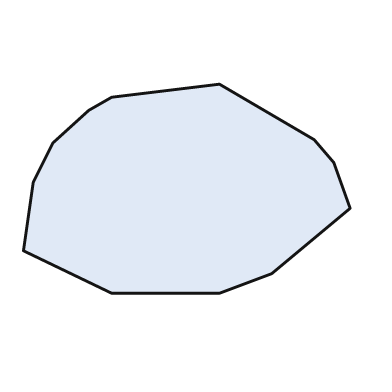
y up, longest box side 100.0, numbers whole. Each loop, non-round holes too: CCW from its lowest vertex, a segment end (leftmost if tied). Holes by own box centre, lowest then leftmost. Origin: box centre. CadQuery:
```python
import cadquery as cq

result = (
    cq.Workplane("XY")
    .moveTo(-23.0, -32.0)
    .lineTo(10.0, -32.0)
    .lineTo(26.0, -26.0)
    .lineTo(50.0, -6.0)
    .lineTo(45.0, 8.0)
    .lineTo(39.0, 15.0)
    .lineTo(10.0, 32.0)
    .lineTo(-23.0, 28.0)
    .lineTo(-30.0, 24.0)
    .lineTo(-41.0, 14.0)
    .lineTo(-47.0, 2.0)
    .lineTo(-50.0, -19.0)
    .close()
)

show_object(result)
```